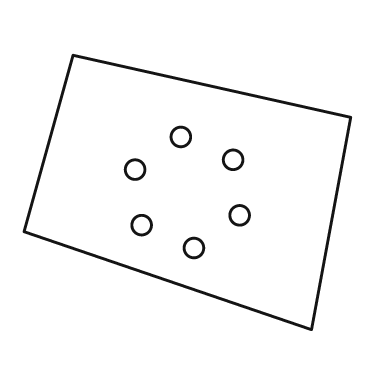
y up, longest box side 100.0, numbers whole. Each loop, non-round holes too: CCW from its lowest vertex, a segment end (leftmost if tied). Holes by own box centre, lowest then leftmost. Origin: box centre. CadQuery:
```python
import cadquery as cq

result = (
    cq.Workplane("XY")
    .moveTo(38.0, -42.0)
    .lineTo(50.0, 23.0)
    .lineTo(-35.0, 42.0)
    .lineTo(-50.0, -12.0)
    .close()
    .moveTo(2.0, -17.0)
    .circle(3.0)
    .moveTo(-14.0, -10.0)
    .circle(3.0)
    .moveTo(16.0, -7.0)
    .circle(3.0)
    .moveTo(-16.0, 7.0)
    .circle(3.0)
    .moveTo(14.0, 10.0)
    .circle(3.0)
    .moveTo(-2.0, 17.0)
    .circle(3.0)
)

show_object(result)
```